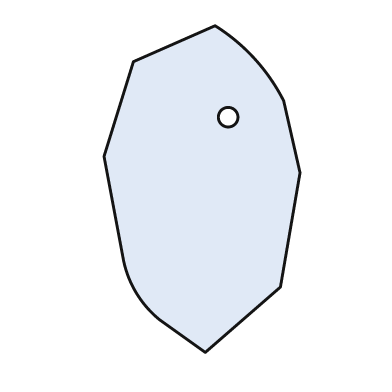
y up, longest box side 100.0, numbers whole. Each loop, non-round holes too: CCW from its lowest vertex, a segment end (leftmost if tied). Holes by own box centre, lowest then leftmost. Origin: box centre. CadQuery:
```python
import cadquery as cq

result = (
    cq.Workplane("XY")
    .moveTo(1.0, -50.0)
    .lineTo(24.0, -30.0)
    .lineTo(30.0, 5.0)
    .lineTo(25.0, 27.0)
    .threePointArc((16.0, 40.0), (4.0, 50.0))
    .lineTo(-21.0, 39.0)
    .lineTo(-30.0, 10.0)
    .lineTo(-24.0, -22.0)
    .threePointArc((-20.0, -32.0), (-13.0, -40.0))
    .close()
    .moveTo(8.0, 22.0)
    .circle(3.0)
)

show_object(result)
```